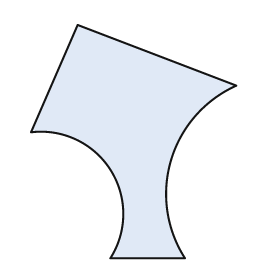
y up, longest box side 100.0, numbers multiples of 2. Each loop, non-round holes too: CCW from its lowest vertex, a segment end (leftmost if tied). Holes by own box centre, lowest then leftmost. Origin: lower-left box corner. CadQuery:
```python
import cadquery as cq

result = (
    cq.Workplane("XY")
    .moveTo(34.0, 0.0)
    .lineTo(66.0, 0.0)
    .threePointArc((60.0, 42.0), (88.0, 74.0))
    .lineTo(20.0, 100.0)
    .lineTo(0.0, 54.0)
    .threePointArc((34.0, 38.0), (34.0, 0.0))
    .close()
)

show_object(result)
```